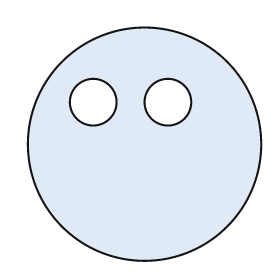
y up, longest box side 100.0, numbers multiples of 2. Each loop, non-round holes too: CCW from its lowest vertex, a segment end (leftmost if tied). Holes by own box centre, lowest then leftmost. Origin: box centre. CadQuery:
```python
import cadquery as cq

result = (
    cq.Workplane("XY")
    .moveTo(0.0, 0.0)
    .circle(50.0)
    .moveTo(-22.0, 18.0)
    .circle(10.0)
    .moveTo(10.0, 18.0)
    .circle(10.0)
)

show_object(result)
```